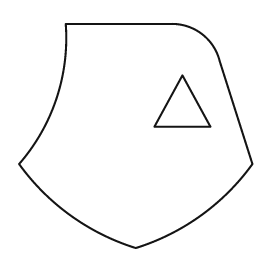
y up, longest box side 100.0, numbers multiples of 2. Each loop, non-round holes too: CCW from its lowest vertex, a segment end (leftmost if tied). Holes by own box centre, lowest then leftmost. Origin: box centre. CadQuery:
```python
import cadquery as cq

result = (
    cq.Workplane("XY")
    .moveTo(0.0, -48.0)
    .threePointArc((28.0, -34.0), (50.0, -12.0))
    .lineTo(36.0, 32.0)
    .threePointArc((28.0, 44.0), (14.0, 48.0))
    .lineTo(-30.0, 48.0)
    .threePointArc((-34.0, 16.0), (-50.0, -12.0))
    .threePointArc((-28.0, -34.0), (0.0, -48.0))
    .close()
    .moveTo(8.0, 4.0)
    .lineTo(32.0, 4.0)
    .lineTo(20.0, 26.0)
    .close()
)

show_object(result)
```